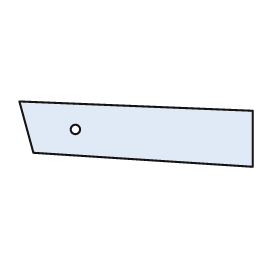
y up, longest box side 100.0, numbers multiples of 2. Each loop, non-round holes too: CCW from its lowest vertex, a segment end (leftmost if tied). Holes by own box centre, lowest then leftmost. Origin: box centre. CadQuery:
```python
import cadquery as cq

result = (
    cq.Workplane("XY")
    .moveTo(50.0, -14.0)
    .lineTo(50.0, 10.0)
    .lineTo(-50.0, 14.0)
    .lineTo(-44.0, -8.0)
    .close()
    .moveTo(-26.0, 2.0)
    .circle(2.0)
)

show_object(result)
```